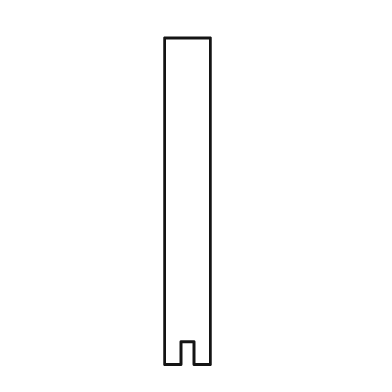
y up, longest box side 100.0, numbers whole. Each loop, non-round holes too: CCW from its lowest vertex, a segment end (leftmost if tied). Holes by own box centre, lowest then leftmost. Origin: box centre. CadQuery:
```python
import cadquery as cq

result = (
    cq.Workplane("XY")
    .moveTo(-7.0, -50.0)
    .lineTo(-2.0, -50.0)
    .lineTo(-2.0, -43.0)
    .lineTo(2.0, -43.0)
    .lineTo(2.0, -50.0)
    .lineTo(7.0, -50.0)
    .lineTo(7.0, 50.0)
    .lineTo(-7.0, 50.0)
    .close()
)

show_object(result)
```